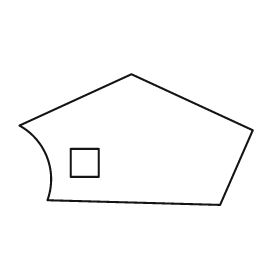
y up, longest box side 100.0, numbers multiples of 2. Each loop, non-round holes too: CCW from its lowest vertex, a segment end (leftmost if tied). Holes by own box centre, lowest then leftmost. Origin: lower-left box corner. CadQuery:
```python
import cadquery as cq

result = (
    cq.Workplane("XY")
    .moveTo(86.0, 0.0)
    .lineTo(100.0, 32.0)
    .lineTo(48.0, 56.0)
    .lineTo(0.0, 34.0)
    .threePointArc((12.0, 20.0), (12.0, 2.0))
    .close()
    .moveTo(22.0, 12.0)
    .lineTo(34.0, 12.0)
    .lineTo(34.0, 24.0)
    .lineTo(22.0, 24.0)
    .close()
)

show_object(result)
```